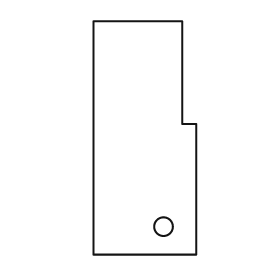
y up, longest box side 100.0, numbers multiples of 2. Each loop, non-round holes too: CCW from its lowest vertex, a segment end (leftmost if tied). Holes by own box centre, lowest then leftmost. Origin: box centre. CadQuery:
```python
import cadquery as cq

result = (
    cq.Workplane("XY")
    .moveTo(-22.0, -50.0)
    .lineTo(22.0, -50.0)
    .lineTo(22.0, 6.0)
    .lineTo(16.0, 6.0)
    .lineTo(16.0, 50.0)
    .lineTo(-22.0, 50.0)
    .close()
    .moveTo(8.0, -38.0)
    .circle(4.0)
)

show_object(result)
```